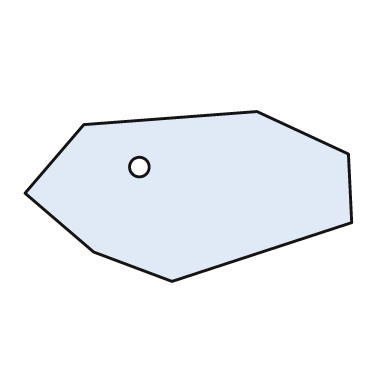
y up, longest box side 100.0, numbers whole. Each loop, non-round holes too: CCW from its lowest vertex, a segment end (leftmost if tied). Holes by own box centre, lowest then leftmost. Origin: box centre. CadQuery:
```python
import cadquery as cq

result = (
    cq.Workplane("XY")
    .moveTo(-5.0, -26.0)
    .lineTo(50.0, -8.0)
    .lineTo(49.0, 13.0)
    .lineTo(21.0, 26.0)
    .lineTo(-32.0, 22.0)
    .lineTo(-50.0, 1.0)
    .lineTo(-29.0, -17.0)
    .close()
    .moveTo(-15.0, 9.0)
    .circle(3.0)
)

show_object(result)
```